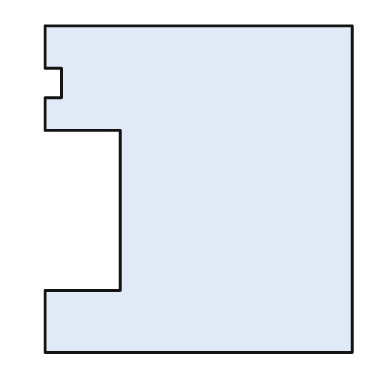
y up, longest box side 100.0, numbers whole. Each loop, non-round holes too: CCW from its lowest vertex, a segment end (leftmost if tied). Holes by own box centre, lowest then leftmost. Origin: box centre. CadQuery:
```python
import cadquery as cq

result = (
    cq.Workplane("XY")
    .moveTo(-47.0, -50.0)
    .lineTo(47.0, -50.0)
    .lineTo(47.0, 50.0)
    .lineTo(-47.0, 50.0)
    .lineTo(-47.0, 37.0)
    .lineTo(-42.0, 37.0)
    .lineTo(-42.0, 28.0)
    .lineTo(-47.0, 28.0)
    .lineTo(-47.0, 18.0)
    .lineTo(-24.0, 18.0)
    .lineTo(-24.0, -31.0)
    .lineTo(-47.0, -31.0)
    .close()
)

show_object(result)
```